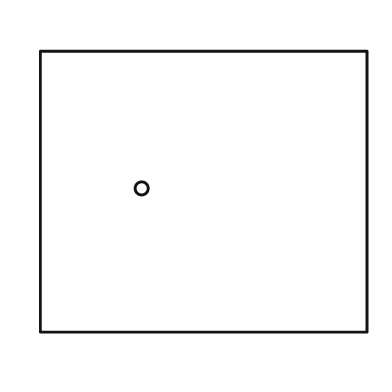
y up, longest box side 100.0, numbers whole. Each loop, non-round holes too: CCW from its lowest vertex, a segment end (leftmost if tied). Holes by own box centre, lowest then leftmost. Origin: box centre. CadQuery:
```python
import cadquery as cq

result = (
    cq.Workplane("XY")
    .moveTo(-50.0, -43.0)
    .lineTo(50.0, -43.0)
    .lineTo(50.0, 43.0)
    .lineTo(-50.0, 43.0)
    .close()
    .moveTo(-19.0, 1.0)
    .circle(2.0)
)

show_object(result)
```